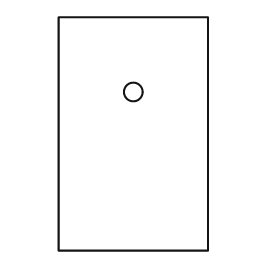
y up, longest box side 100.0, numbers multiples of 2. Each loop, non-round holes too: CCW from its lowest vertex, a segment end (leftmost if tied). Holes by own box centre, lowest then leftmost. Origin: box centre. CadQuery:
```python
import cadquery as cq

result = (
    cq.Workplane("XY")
    .moveTo(-32.0, -50.0)
    .lineTo(32.0, -50.0)
    .lineTo(32.0, 50.0)
    .lineTo(-32.0, 50.0)
    .close()
    .moveTo(0.0, 18.0)
    .circle(4.0)
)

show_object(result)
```